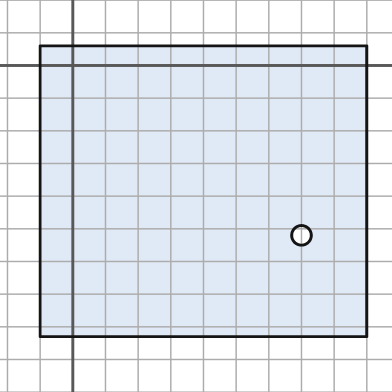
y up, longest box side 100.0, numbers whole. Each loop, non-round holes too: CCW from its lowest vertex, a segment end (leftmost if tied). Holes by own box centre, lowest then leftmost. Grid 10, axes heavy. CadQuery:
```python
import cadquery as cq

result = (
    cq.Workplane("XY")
    .moveTo(-10.0, -83.0)
    .lineTo(90.0, -83.0)
    .lineTo(90.0, 6.0)
    .lineTo(-10.0, 6.0)
    .close()
    .moveTo(70.0, -52.0)
    .circle(3.0)
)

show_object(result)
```